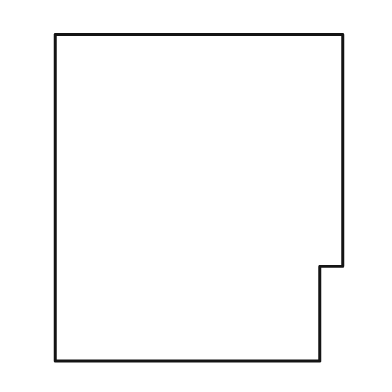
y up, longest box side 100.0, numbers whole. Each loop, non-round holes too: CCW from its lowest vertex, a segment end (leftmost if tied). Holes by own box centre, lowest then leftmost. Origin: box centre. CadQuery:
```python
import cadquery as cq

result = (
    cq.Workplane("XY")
    .moveTo(-44.0, -50.0)
    .lineTo(37.0, -50.0)
    .lineTo(37.0, -21.0)
    .lineTo(44.0, -21.0)
    .lineTo(44.0, 50.0)
    .lineTo(-44.0, 50.0)
    .close()
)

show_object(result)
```